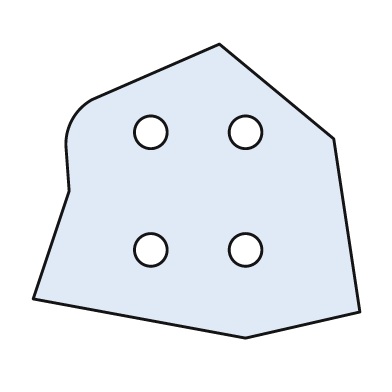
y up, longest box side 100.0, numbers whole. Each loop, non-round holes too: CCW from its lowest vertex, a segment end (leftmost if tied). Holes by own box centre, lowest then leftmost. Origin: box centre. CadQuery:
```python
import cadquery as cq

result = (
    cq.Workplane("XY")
    .moveTo(15.0, -45.0)
    .lineTo(50.0, -37.0)
    .lineTo(42.0, 16.0)
    .lineTo(7.0, 45.0)
    .lineTo(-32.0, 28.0)
    .threePointArc((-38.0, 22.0), (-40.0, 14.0))
    .lineTo(-39.0, 0.0)
    .lineTo(-50.0, -33.0)
    .close()
    .moveTo(-14.0, -18.0)
    .circle(5.0)
    .moveTo(15.0, -18.0)
    .circle(5.0)
    .moveTo(-14.0, 18.0)
    .circle(5.0)
    .moveTo(15.0, 18.0)
    .circle(5.0)
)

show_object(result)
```